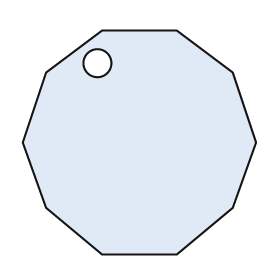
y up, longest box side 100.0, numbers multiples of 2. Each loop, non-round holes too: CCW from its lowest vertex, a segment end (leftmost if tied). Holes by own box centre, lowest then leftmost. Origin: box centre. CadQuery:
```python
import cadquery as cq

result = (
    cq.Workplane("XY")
    .moveTo(-16.0, -48.0)
    .lineTo(16.0, -48.0)
    .lineTo(40.0, -28.0)
    .lineTo(50.0, 0.0)
    .lineTo(40.0, 30.0)
    .lineTo(16.0, 48.0)
    .lineTo(-16.0, 48.0)
    .lineTo(-40.0, 30.0)
    .lineTo(-50.0, 0.0)
    .lineTo(-40.0, -28.0)
    .close()
    .moveTo(-18.0, 34.0)
    .circle(6.0)
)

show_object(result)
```